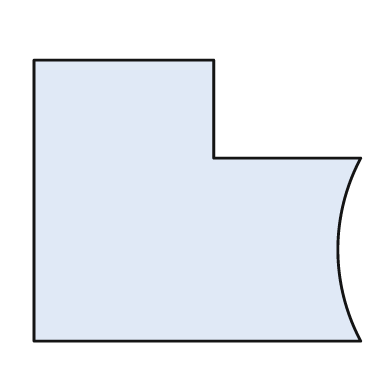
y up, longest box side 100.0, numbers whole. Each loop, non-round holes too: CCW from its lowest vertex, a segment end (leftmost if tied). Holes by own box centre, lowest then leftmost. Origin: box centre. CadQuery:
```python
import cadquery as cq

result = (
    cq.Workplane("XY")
    .moveTo(-50.0, -43.0)
    .lineTo(50.0, -43.0)
    .threePointArc((43.0, -15.0), (50.0, 13.0))
    .lineTo(5.0, 13.0)
    .lineTo(5.0, 43.0)
    .lineTo(-50.0, 43.0)
    .close()
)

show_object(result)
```